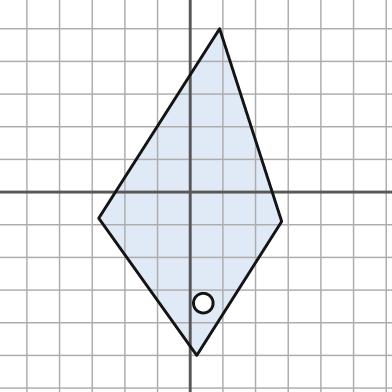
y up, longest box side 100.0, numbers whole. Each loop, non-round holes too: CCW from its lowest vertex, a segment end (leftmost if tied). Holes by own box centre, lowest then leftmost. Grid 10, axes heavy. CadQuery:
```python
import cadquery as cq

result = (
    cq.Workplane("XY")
    .moveTo(2.0, -50.0)
    .lineTo(28.0, -9.0)
    .lineTo(9.0, 50.0)
    .lineTo(-28.0, -8.0)
    .close()
    .moveTo(4.0, -34.0)
    .circle(3.0)
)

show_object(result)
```